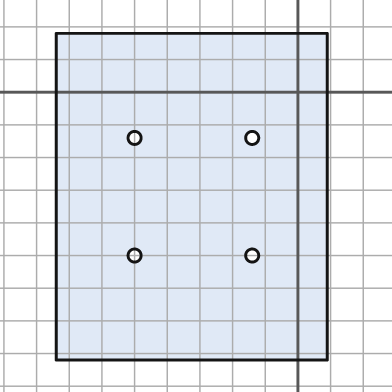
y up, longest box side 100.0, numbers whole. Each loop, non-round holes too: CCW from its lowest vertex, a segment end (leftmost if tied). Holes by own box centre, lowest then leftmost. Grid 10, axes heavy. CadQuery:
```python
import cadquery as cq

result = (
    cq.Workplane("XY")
    .moveTo(-74.0, -82.0)
    .lineTo(9.0, -82.0)
    .lineTo(9.0, 18.0)
    .lineTo(-74.0, 18.0)
    .close()
    .moveTo(-50.0, -50.0)
    .circle(2.0)
    .moveTo(-14.0, -50.0)
    .circle(2.0)
    .moveTo(-50.0, -14.0)
    .circle(2.0)
    .moveTo(-14.0, -14.0)
    .circle(2.0)
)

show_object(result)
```